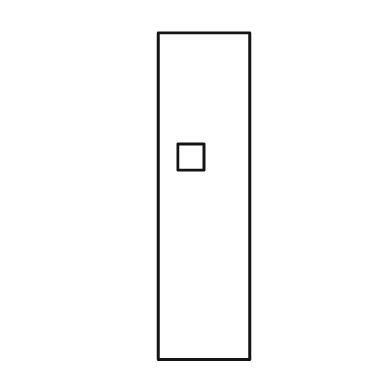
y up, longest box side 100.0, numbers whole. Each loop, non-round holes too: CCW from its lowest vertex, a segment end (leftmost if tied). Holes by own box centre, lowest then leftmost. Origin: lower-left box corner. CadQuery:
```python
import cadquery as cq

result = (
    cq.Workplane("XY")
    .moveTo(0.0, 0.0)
    .lineTo(28.0, 0.0)
    .lineTo(28.0, 100.0)
    .lineTo(0.0, 100.0)
    .close()
    .moveTo(6.0, 58.0)
    .lineTo(14.0, 58.0)
    .lineTo(14.0, 66.0)
    .lineTo(6.0, 66.0)
    .close()
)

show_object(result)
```